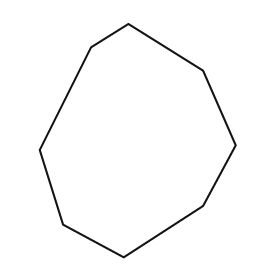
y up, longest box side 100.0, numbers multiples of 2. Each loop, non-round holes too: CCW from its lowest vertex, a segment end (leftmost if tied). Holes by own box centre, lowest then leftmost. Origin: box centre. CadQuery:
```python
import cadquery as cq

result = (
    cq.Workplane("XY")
    .moveTo(-6.0, -50.0)
    .lineTo(28.0, -28.0)
    .lineTo(42.0, -2.0)
    .lineTo(28.0, 30.0)
    .lineTo(-4.0, 50.0)
    .lineTo(-20.0, 40.0)
    .lineTo(-42.0, -4.0)
    .lineTo(-32.0, -36.0)
    .close()
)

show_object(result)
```